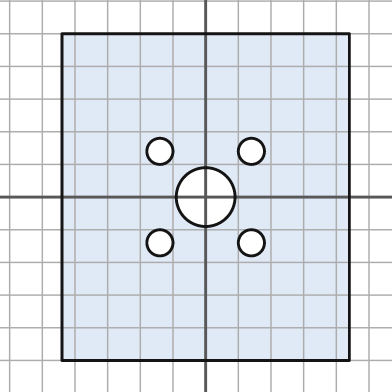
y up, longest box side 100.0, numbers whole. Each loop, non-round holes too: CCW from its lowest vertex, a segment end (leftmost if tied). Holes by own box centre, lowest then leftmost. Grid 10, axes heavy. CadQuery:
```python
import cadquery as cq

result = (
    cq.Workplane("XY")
    .moveTo(-44.0, -50.0)
    .lineTo(44.0, -50.0)
    .lineTo(44.0, 50.0)
    .lineTo(-44.0, 50.0)
    .close()
    .moveTo(-14.0, -14.0)
    .circle(4.0)
    .moveTo(14.0, -14.0)
    .circle(4.0)
    .moveTo(0.0, 0.0)
    .circle(9.0)
    .moveTo(-14.0, 14.0)
    .circle(4.0)
    .moveTo(14.0, 14.0)
    .circle(4.0)
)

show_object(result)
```